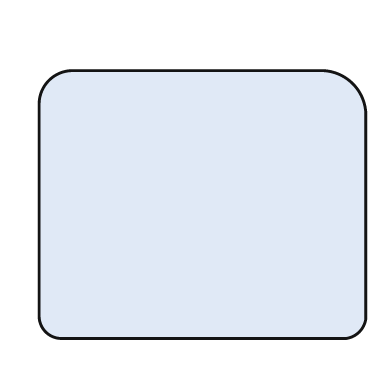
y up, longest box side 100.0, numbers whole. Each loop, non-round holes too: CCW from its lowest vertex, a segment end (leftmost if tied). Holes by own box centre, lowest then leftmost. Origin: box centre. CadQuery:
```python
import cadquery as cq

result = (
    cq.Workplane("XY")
    .moveTo(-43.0, -41.0)
    .lineTo(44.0, -41.0)
    .threePointArc((48.0, -39.0), (50.0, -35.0))
    .lineTo(50.0, 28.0)
    .threePointArc((46.0, 37.0), (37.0, 41.0))
    .lineTo(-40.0, 41.0)
    .threePointArc((-47.0, 38.0), (-50.0, 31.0))
    .lineTo(-50.0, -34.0)
    .threePointArc((-48.0, -39.0), (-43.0, -41.0))
    .close()
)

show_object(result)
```